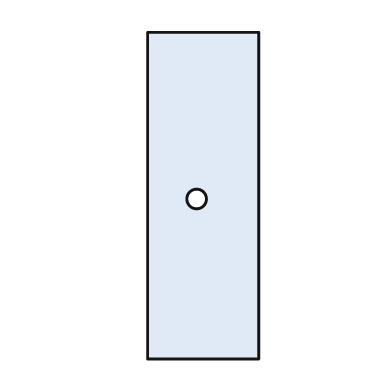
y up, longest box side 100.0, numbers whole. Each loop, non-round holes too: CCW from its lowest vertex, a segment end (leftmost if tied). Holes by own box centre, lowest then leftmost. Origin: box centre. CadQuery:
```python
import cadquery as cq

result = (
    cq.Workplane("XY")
    .moveTo(-17.0, -50.0)
    .lineTo(17.0, -50.0)
    .lineTo(17.0, 50.0)
    .lineTo(-17.0, 50.0)
    .close()
    .moveTo(-2.0, -1.0)
    .circle(3.0)
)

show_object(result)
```